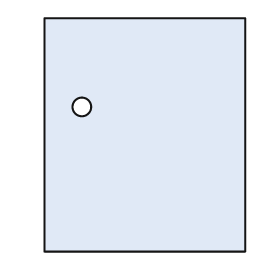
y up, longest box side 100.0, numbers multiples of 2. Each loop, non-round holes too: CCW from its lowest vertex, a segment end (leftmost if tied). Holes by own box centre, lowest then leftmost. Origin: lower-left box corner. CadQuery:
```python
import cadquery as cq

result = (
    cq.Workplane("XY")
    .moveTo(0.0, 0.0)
    .lineTo(86.0, 0.0)
    .lineTo(86.0, 100.0)
    .lineTo(0.0, 100.0)
    .close()
    .moveTo(16.0, 62.0)
    .circle(4.0)
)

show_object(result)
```